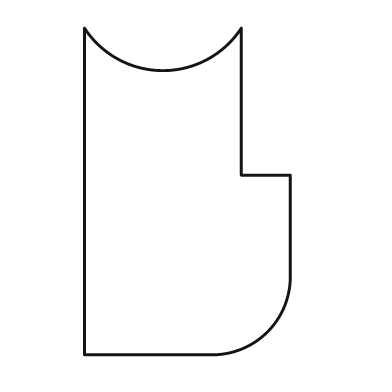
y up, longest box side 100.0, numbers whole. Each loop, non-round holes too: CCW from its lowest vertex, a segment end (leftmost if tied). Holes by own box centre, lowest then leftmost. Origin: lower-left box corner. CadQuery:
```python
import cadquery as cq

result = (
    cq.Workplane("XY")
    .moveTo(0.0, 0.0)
    .lineTo(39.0, 0.0)
    .threePointArc((56.0, 7.0), (63.0, 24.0))
    .lineTo(63.0, 55.0)
    .lineTo(48.0, 55.0)
    .lineTo(48.0, 100.0)
    .threePointArc((24.0, 87.0), (0.0, 100.0))
    .close()
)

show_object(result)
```